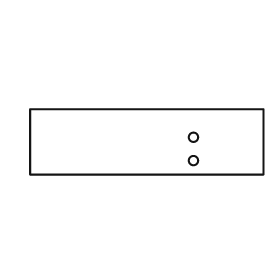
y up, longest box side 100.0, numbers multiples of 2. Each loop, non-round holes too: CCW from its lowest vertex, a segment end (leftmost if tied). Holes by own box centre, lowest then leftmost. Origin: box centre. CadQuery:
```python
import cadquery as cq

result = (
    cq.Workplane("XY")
    .moveTo(-50.0, -14.0)
    .lineTo(50.0, -14.0)
    .lineTo(50.0, 14.0)
    .lineTo(-50.0, 14.0)
    .close()
    .moveTo(20.0, -8.0)
    .circle(2.0)
    .moveTo(20.0, 2.0)
    .circle(2.0)
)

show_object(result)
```